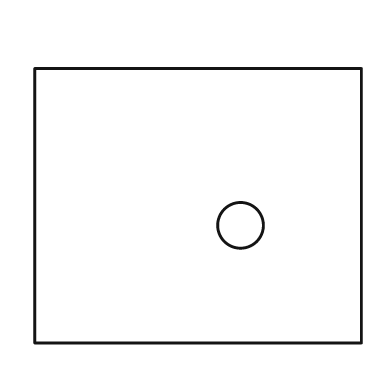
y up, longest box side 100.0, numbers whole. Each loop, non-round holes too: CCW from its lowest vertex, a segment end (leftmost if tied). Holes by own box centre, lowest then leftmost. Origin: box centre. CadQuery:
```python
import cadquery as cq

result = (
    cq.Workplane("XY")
    .moveTo(-50.0, -42.0)
    .lineTo(50.0, -42.0)
    .lineTo(50.0, 42.0)
    .lineTo(-50.0, 42.0)
    .close()
    .moveTo(13.0, -6.0)
    .circle(7.0)
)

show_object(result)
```